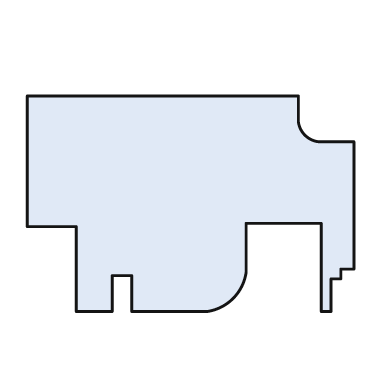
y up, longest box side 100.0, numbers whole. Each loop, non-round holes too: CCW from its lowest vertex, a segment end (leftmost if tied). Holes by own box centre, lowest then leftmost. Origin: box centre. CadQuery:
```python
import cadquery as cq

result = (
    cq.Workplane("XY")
    .moveTo(-35.0, -33.0)
    .lineTo(-24.0, -33.0)
    .lineTo(-24.0, -22.0)
    .lineTo(-18.0, -22.0)
    .lineTo(-18.0, -33.0)
    .lineTo(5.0, -33.0)
    .threePointArc((13.0, -29.0), (17.0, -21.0))
    .lineTo(17.0, -6.0)
    .lineTo(40.0, -6.0)
    .lineTo(40.0, -33.0)
    .lineTo(43.0, -33.0)
    .lineTo(43.0, -23.0)
    .lineTo(46.0, -23.0)
    .lineTo(46.0, -20.0)
    .lineTo(50.0, -20.0)
    .lineTo(50.0, 19.0)
    .lineTo(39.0, 19.0)
    .threePointArc((35.0, 21.0), (33.0, 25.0))
    .lineTo(33.0, 33.0)
    .lineTo(-50.0, 33.0)
    .lineTo(-50.0, -7.0)
    .lineTo(-35.0, -7.0)
    .close()
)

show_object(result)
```